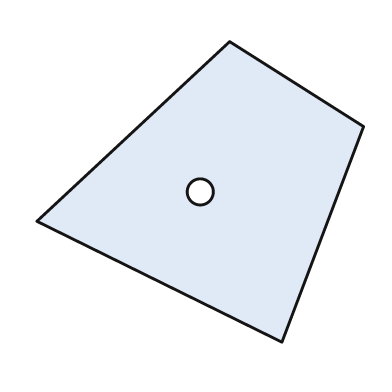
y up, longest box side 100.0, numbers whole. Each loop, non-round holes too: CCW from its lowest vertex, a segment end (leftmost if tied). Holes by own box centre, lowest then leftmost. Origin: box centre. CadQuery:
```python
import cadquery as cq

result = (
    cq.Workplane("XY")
    .moveTo(25.0, -46.0)
    .lineTo(50.0, 20.0)
    .lineTo(9.0, 46.0)
    .lineTo(-50.0, -9.0)
    .close()
    .moveTo(0.0, 0.0)
    .circle(4.0)
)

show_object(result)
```